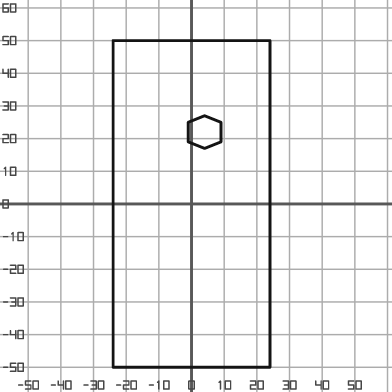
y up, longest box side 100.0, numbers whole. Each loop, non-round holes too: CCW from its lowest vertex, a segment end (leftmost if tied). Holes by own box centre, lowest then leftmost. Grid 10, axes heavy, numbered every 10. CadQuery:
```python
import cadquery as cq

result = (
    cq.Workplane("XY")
    .moveTo(-24.0, -50.0)
    .lineTo(24.0, -50.0)
    .lineTo(24.0, 50.0)
    .lineTo(-24.0, 50.0)
    .close()
    .moveTo(4.0, 17.0)
    .lineTo(9.0, 19.0)
    .lineTo(9.0, 25.0)
    .lineTo(4.0, 27.0)
    .lineTo(-1.0, 25.0)
    .lineTo(-1.0, 19.0)
    .close()
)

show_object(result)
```